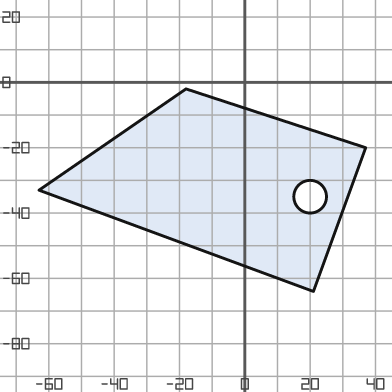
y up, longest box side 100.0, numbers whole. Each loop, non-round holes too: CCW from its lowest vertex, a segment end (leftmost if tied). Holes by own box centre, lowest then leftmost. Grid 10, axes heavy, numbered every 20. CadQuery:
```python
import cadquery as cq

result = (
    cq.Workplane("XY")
    .moveTo(21.0, -64.0)
    .lineTo(37.0, -20.0)
    .lineTo(-18.0, -2.0)
    .lineTo(-63.0, -33.0)
    .close()
    .moveTo(20.0, -35.0)
    .circle(5.0)
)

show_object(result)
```